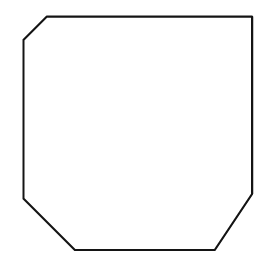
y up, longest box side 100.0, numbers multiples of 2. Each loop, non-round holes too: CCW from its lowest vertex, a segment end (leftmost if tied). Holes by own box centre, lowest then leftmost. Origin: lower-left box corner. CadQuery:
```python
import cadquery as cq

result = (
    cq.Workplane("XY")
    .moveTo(22.0, 0.0)
    .lineTo(82.0, 0.0)
    .lineTo(98.0, 24.0)
    .lineTo(98.0, 100.0)
    .lineTo(10.0, 100.0)
    .lineTo(0.0, 90.0)
    .lineTo(0.0, 22.0)
    .close()
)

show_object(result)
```